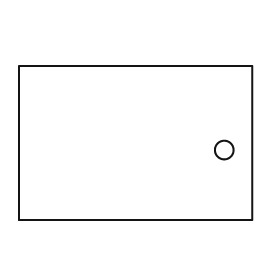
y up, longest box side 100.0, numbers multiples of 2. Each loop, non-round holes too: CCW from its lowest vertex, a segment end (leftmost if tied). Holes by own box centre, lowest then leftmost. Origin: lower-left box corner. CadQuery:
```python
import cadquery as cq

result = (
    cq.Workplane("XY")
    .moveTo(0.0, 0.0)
    .lineTo(100.0, 0.0)
    .lineTo(100.0, 66.0)
    .lineTo(0.0, 66.0)
    .close()
    .moveTo(88.0, 30.0)
    .circle(4.0)
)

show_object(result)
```